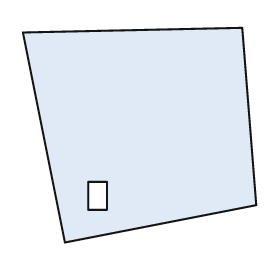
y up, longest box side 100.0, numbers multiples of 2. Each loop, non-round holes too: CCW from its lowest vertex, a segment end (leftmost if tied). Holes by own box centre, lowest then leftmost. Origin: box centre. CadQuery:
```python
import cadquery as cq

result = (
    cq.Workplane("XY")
    .moveTo(-32.0, -46.0)
    .lineTo(50.0, -30.0)
    .lineTo(44.0, 46.0)
    .lineTo(-50.0, 44.0)
    .close()
    .moveTo(-22.0, -32.0)
    .lineTo(-14.0, -32.0)
    .lineTo(-14.0, -20.0)
    .lineTo(-22.0, -20.0)
    .close()
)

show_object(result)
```